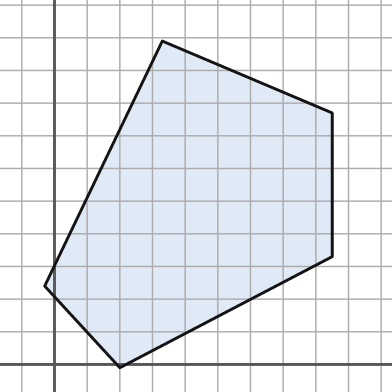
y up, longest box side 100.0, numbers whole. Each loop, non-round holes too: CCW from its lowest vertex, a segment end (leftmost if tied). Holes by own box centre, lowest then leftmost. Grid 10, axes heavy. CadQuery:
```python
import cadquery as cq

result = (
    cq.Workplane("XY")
    .moveTo(20.0, -1.0)
    .lineTo(85.0, 33.0)
    .lineTo(85.0, 77.0)
    .lineTo(33.0, 99.0)
    .lineTo(-3.0, 24.0)
    .close()
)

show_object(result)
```